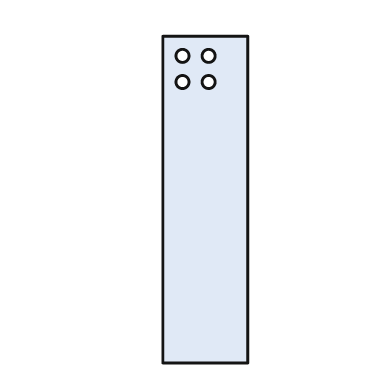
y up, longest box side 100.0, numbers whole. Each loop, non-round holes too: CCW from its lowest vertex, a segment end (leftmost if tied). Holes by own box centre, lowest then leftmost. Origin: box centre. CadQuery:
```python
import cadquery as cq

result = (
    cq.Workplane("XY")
    .moveTo(-13.0, -50.0)
    .lineTo(13.0, -50.0)
    .lineTo(13.0, 50.0)
    .lineTo(-13.0, 50.0)
    .close()
    .moveTo(-7.0, 36.0)
    .circle(2.0)
    .moveTo(1.0, 36.0)
    .circle(2.0)
    .moveTo(-7.0, 44.0)
    .circle(2.0)
    .moveTo(1.0, 44.0)
    .circle(2.0)
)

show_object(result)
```